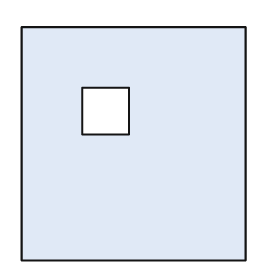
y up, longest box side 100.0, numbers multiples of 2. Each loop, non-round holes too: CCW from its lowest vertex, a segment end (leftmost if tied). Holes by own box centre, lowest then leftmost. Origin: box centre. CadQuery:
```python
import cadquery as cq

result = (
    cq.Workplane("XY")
    .moveTo(-48.0, -50.0)
    .lineTo(48.0, -50.0)
    .lineTo(48.0, 50.0)
    .lineTo(-48.0, 50.0)
    .close()
    .moveTo(-22.0, 4.0)
    .lineTo(-2.0, 4.0)
    .lineTo(-2.0, 24.0)
    .lineTo(-22.0, 24.0)
    .close()
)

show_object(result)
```